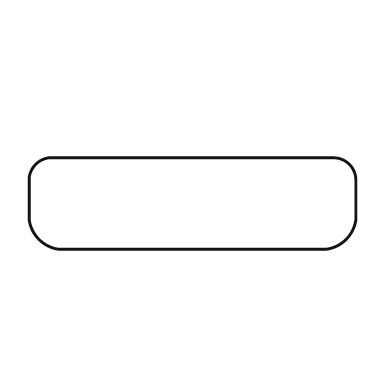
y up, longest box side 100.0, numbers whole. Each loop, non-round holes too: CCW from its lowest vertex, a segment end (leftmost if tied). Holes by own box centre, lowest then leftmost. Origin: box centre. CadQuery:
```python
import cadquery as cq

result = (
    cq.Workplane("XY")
    .moveTo(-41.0, -14.0)
    .lineTo(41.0, -14.0)
    .threePointArc((47.0, -11.0), (50.0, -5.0))
    .lineTo(50.0, 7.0)
    .threePointArc((48.0, 12.0), (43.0, 14.0))
    .lineTo(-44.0, 14.0)
    .threePointArc((-48.0, 12.0), (-50.0, 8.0))
    .lineTo(-50.0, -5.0)
    .threePointArc((-47.0, -11.0), (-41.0, -14.0))
    .close()
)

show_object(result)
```